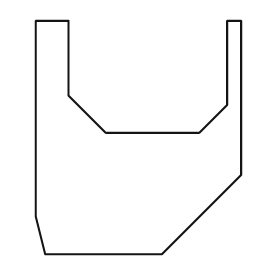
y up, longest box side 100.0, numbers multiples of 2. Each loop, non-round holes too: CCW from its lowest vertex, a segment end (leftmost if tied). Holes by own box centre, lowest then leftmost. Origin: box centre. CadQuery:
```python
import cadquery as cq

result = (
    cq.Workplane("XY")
    .moveTo(-40.0, -50.0)
    .lineTo(10.0, -50.0)
    .lineTo(44.0, -16.0)
    .lineTo(44.0, 50.0)
    .lineTo(38.0, 50.0)
    .lineTo(38.0, 14.0)
    .lineTo(26.0, 2.0)
    .lineTo(-14.0, 2.0)
    .lineTo(-30.0, 18.0)
    .lineTo(-30.0, 50.0)
    .lineTo(-44.0, 50.0)
    .lineTo(-44.0, -34.0)
    .close()
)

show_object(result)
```